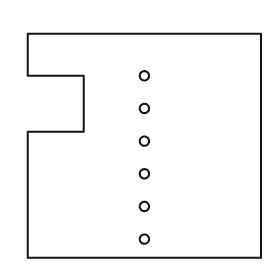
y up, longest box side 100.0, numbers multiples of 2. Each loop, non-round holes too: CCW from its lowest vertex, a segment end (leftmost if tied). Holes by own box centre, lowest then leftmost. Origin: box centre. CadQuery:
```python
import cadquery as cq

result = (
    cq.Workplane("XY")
    .moveTo(-50.0, -48.0)
    .lineTo(50.0, -48.0)
    .lineTo(50.0, 48.0)
    .lineTo(-50.0, 48.0)
    .lineTo(-50.0, 30.0)
    .lineTo(-26.0, 30.0)
    .lineTo(-26.0, 6.0)
    .lineTo(-50.0, 6.0)
    .close()
    .moveTo(0.0, -40.0)
    .circle(2.0)
    .moveTo(0.0, -26.0)
    .circle(2.0)
    .moveTo(0.0, -12.0)
    .circle(2.0)
    .moveTo(0.0, 2.0)
    .circle(2.0)
    .moveTo(0.0, 16.0)
    .circle(2.0)
    .moveTo(0.0, 30.0)
    .circle(2.0)
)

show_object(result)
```